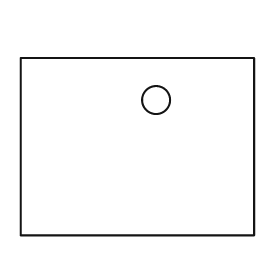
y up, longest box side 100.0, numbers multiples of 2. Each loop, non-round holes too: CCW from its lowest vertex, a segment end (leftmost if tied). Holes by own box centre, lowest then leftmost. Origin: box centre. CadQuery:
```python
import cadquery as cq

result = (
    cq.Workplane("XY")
    .moveTo(-50.0, -38.0)
    .lineTo(50.0, -38.0)
    .lineTo(50.0, 38.0)
    .lineTo(-50.0, 38.0)
    .close()
    .moveTo(8.0, 20.0)
    .circle(6.0)
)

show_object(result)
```